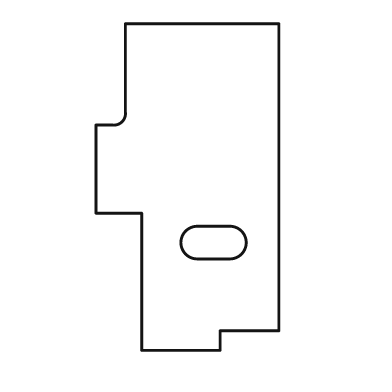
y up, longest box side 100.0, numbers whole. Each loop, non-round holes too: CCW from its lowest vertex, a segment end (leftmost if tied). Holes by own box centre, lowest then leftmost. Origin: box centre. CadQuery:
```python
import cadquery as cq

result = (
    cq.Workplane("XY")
    .moveTo(-14.0, -50.0)
    .lineTo(10.0, -50.0)
    .lineTo(10.0, -44.0)
    .lineTo(28.0, -44.0)
    .lineTo(28.0, 50.0)
    .lineTo(-19.0, 50.0)
    .lineTo(-19.0, 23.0)
    .threePointArc((-20.0, 20.0), (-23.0, 19.0))
    .lineTo(-28.0, 19.0)
    .lineTo(-28.0, -8.0)
    .lineTo(-14.0, -8.0)
    .close()
    .moveTo(3.0, -22.0)
    .lineTo(13.0, -22.0)
    .threePointArc((18.0, -17.0), (13.0, -12.0))
    .lineTo(3.0, -12.0)
    .threePointArc((-2.0, -17.0), (3.0, -22.0))
    .close()
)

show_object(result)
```